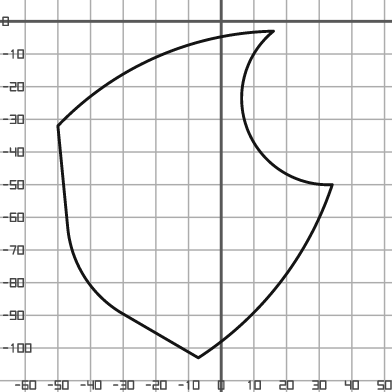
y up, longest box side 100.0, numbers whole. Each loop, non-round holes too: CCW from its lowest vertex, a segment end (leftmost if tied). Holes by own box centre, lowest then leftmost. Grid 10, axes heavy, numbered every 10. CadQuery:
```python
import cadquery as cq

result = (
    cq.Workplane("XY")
    .moveTo(-7.0, -103.0)
    .threePointArc((18.0, -80.0), (34.0, -50.0))
    .threePointArc((8.0, -33.0), (16.0, -3.0))
    .threePointArc((-20.0, -11.0), (-50.0, -32.0))
    .lineTo(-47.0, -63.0)
    .threePointArc((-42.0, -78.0), (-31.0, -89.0))
    .close()
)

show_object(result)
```